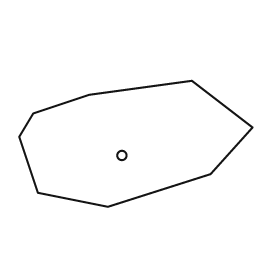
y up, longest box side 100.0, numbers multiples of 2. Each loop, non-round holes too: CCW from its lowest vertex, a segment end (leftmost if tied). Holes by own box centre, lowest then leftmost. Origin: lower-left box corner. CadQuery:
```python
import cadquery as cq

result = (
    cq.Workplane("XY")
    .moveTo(38.0, 0.0)
    .lineTo(82.0, 14.0)
    .lineTo(100.0, 34.0)
    .lineTo(74.0, 54.0)
    .lineTo(30.0, 48.0)
    .lineTo(6.0, 40.0)
    .lineTo(0.0, 30.0)
    .lineTo(8.0, 6.0)
    .close()
    .moveTo(44.0, 22.0)
    .circle(2.0)
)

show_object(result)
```